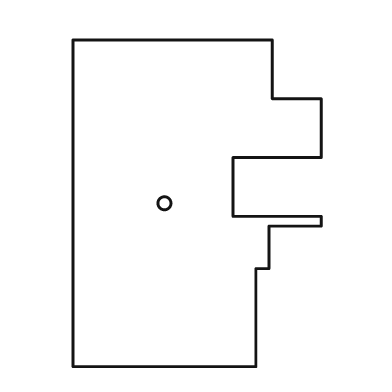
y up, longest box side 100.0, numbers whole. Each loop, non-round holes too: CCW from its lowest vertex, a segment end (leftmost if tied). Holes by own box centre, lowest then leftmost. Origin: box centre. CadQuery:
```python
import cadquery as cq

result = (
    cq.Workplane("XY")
    .moveTo(-38.0, -50.0)
    .lineTo(18.0, -50.0)
    .lineTo(18.0, -20.0)
    .lineTo(22.0, -20.0)
    .lineTo(22.0, -7.0)
    .lineTo(38.0, -7.0)
    .lineTo(38.0, -4.0)
    .lineTo(11.0, -4.0)
    .lineTo(11.0, 14.0)
    .lineTo(38.0, 14.0)
    .lineTo(38.0, 32.0)
    .lineTo(23.0, 32.0)
    .lineTo(23.0, 50.0)
    .lineTo(-38.0, 50.0)
    .close()
    .moveTo(-10.0, 0.0)
    .circle(2.0)
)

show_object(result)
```